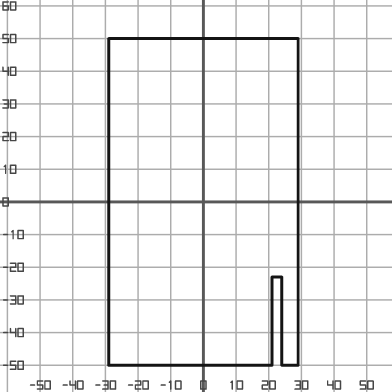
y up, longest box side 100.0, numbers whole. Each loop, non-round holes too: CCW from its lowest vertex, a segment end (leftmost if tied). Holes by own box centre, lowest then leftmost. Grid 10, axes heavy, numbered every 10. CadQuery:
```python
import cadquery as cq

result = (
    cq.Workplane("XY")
    .moveTo(-29.0, -50.0)
    .lineTo(21.0, -50.0)
    .lineTo(21.0, -23.0)
    .lineTo(24.0, -23.0)
    .lineTo(24.0, -50.0)
    .lineTo(29.0, -50.0)
    .lineTo(29.0, 50.0)
    .lineTo(-29.0, 50.0)
    .close()
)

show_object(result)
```